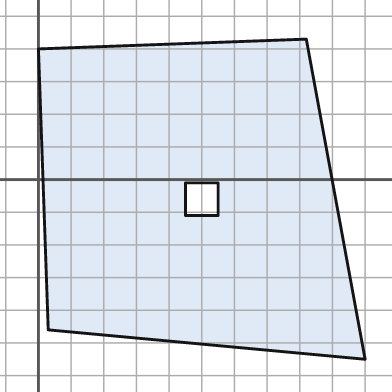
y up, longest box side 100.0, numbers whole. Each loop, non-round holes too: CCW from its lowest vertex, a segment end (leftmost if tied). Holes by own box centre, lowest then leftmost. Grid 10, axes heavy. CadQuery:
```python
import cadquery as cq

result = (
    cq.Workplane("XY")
    .moveTo(100.0, -55.0)
    .lineTo(82.0, 43.0)
    .lineTo(0.0, 40.0)
    .lineTo(3.0, -46.0)
    .close()
    .moveTo(45.0, -11.0)
    .lineTo(55.0, -11.0)
    .lineTo(55.0, -1.0)
    .lineTo(45.0, -1.0)
    .close()
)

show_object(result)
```